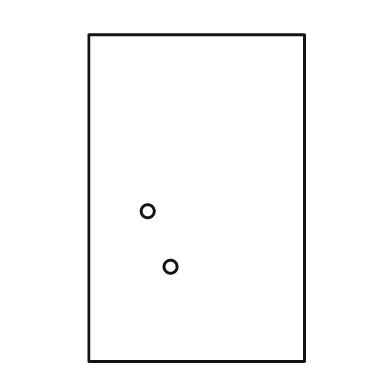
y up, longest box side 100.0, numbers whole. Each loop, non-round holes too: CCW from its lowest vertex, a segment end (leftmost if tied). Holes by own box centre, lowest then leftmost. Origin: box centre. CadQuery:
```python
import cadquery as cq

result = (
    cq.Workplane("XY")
    .moveTo(-33.0, -50.0)
    .lineTo(33.0, -50.0)
    .lineTo(33.0, 50.0)
    .lineTo(-33.0, 50.0)
    .close()
    .moveTo(-8.0, -21.0)
    .circle(2.0)
    .moveTo(-15.0, -4.0)
    .circle(2.0)
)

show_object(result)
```